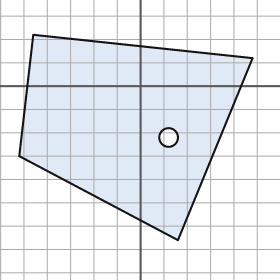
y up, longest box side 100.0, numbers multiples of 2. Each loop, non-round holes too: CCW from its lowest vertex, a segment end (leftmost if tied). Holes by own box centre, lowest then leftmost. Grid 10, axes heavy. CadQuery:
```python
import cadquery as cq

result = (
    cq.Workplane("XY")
    .moveTo(16.0, -66.0)
    .lineTo(48.0, 12.0)
    .lineTo(-46.0, 22.0)
    .lineTo(-52.0, -30.0)
    .close()
    .moveTo(12.0, -22.0)
    .circle(4.0)
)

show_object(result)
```